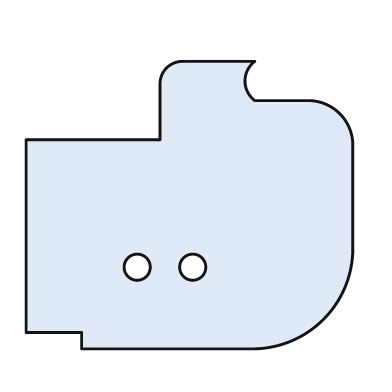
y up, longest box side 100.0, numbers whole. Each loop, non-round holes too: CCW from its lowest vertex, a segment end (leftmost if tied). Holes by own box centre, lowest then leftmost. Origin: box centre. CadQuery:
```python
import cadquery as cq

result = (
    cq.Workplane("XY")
    .moveTo(-33.0, -44.0)
    .lineTo(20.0, -44.0)
    .threePointArc((41.0, -35.0), (50.0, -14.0))
    .lineTo(50.0, 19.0)
    .threePointArc((46.0, 28.0), (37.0, 32.0))
    .lineTo(20.0, 32.0)
    .threePointArc((17.0, 38.0), (20.0, 44.0))
    .lineTo(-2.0, 44.0)
    .threePointArc((-7.0, 42.0), (-9.0, 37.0))
    .lineTo(-9.0, 20.0)
    .lineTo(-50.0, 20.0)
    .lineTo(-50.0, -39.0)
    .lineTo(-33.0, -39.0)
    .close()
    .moveTo(-16.0, -19.0)
    .circle(4.0)
    .moveTo(1.0, -19.0)
    .circle(4.0)
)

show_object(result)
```